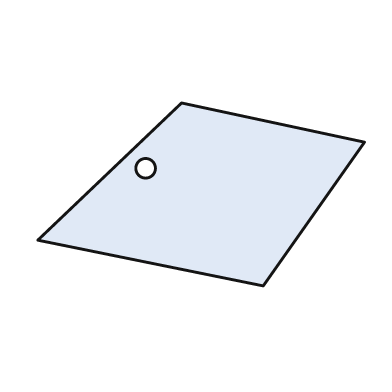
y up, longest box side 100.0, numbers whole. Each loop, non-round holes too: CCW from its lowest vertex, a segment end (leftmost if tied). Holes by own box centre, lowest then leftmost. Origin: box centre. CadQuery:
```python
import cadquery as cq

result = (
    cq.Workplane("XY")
    .moveTo(19.0, -28.0)
    .lineTo(50.0, 16.0)
    .lineTo(-6.0, 28.0)
    .lineTo(-50.0, -14.0)
    .close()
    .moveTo(-17.0, 8.0)
    .circle(3.0)
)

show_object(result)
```